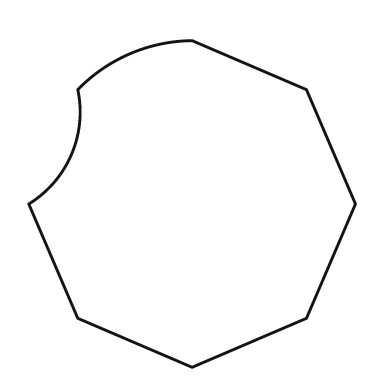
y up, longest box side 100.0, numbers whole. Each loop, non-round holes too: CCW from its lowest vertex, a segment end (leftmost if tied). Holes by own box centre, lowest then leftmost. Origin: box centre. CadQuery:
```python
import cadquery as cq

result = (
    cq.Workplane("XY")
    .moveTo(0.0, -50.0)
    .lineTo(35.0, -35.0)
    .lineTo(50.0, 0.0)
    .lineTo(35.0, 35.0)
    .lineTo(0.0, 50.0)
    .threePointArc((-19.0, 46.0), (-35.0, 35.0))
    .threePointArc((-37.0, 15.0), (-50.0, 0.0))
    .lineTo(-35.0, -35.0)
    .close()
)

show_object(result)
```